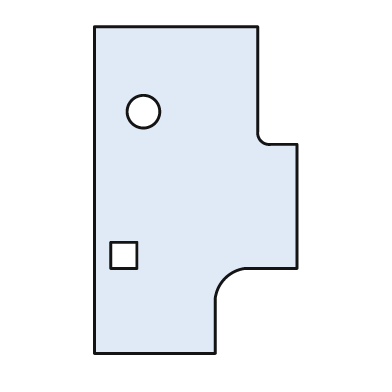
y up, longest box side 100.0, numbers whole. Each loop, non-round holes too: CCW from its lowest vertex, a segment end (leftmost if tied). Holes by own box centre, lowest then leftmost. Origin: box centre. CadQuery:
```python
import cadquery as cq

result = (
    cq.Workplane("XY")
    .moveTo(-31.0, -50.0)
    .lineTo(6.0, -50.0)
    .lineTo(6.0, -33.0)
    .threePointArc((9.0, -27.0), (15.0, -24.0))
    .lineTo(31.0, -24.0)
    .lineTo(31.0, 14.0)
    .lineTo(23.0, 14.0)
    .threePointArc((20.0, 15.0), (19.0, 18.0))
    .lineTo(19.0, 50.0)
    .lineTo(-31.0, 50.0)
    .close()
    .moveTo(-26.0, -24.0)
    .lineTo(-18.0, -24.0)
    .lineTo(-18.0, -16.0)
    .lineTo(-26.0, -16.0)
    .close()
    .moveTo(-16.0, 24.0)
    .circle(5.0)
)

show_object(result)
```